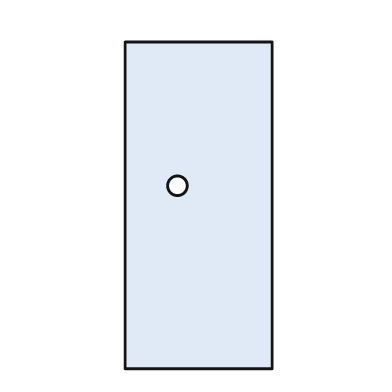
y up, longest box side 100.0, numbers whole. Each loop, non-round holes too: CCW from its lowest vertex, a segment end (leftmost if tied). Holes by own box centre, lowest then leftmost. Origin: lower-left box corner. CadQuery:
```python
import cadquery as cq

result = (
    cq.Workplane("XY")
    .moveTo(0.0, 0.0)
    .lineTo(45.0, 0.0)
    .lineTo(45.0, 100.0)
    .lineTo(0.0, 100.0)
    .close()
    .moveTo(16.0, 56.0)
    .circle(3.0)
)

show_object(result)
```